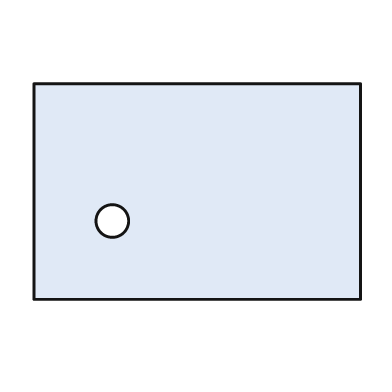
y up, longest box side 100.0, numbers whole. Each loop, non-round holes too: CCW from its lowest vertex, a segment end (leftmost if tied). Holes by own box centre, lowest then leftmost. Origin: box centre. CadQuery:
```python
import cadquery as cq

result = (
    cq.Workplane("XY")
    .moveTo(-50.0, -33.0)
    .lineTo(50.0, -33.0)
    .lineTo(50.0, 33.0)
    .lineTo(-50.0, 33.0)
    .close()
    .moveTo(-26.0, -9.0)
    .circle(5.0)
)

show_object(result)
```